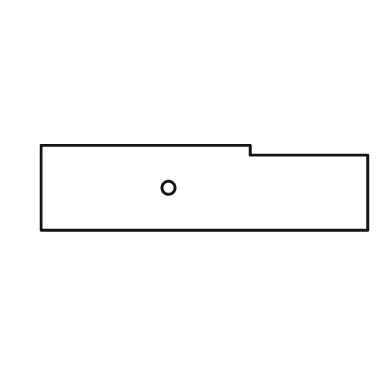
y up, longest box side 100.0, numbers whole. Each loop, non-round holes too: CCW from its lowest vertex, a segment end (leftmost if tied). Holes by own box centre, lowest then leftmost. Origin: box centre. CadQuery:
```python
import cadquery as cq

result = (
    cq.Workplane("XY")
    .moveTo(-50.0, -13.0)
    .lineTo(50.0, -13.0)
    .lineTo(50.0, 10.0)
    .lineTo(14.0, 10.0)
    .lineTo(14.0, 13.0)
    .lineTo(-50.0, 13.0)
    .close()
    .moveTo(-11.0, 0.0)
    .circle(2.0)
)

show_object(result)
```